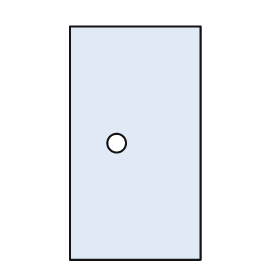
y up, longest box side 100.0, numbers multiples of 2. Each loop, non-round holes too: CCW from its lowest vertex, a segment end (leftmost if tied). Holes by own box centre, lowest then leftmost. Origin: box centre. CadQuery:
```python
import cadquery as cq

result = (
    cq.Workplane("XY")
    .moveTo(-28.0, -50.0)
    .lineTo(28.0, -50.0)
    .lineTo(28.0, 50.0)
    .lineTo(-28.0, 50.0)
    .close()
    .moveTo(-8.0, 0.0)
    .circle(4.0)
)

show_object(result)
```